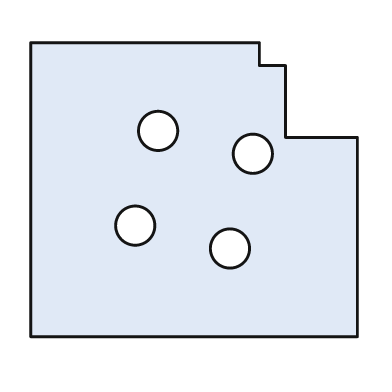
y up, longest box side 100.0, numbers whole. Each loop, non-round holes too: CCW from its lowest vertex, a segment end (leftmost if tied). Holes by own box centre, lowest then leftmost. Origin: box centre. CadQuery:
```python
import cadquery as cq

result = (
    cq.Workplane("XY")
    .moveTo(-50.0, -45.0)
    .lineTo(50.0, -45.0)
    .lineTo(50.0, 16.0)
    .lineTo(28.0, 16.0)
    .lineTo(28.0, 38.0)
    .lineTo(20.0, 38.0)
    .lineTo(20.0, 45.0)
    .lineTo(-50.0, 45.0)
    .close()
    .moveTo(11.0, -18.0)
    .circle(6.0)
    .moveTo(-18.0, -11.0)
    .circle(6.0)
    .moveTo(18.0, 11.0)
    .circle(6.0)
    .moveTo(-11.0, 18.0)
    .circle(6.0)
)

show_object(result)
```